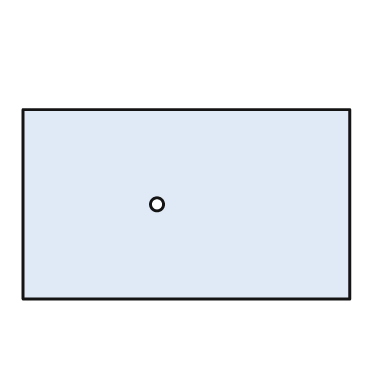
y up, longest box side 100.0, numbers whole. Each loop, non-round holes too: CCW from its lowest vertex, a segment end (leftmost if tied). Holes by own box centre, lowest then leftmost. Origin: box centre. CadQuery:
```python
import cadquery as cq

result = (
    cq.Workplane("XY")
    .moveTo(-50.0, -29.0)
    .lineTo(50.0, -29.0)
    .lineTo(50.0, 29.0)
    .lineTo(-50.0, 29.0)
    .close()
    .moveTo(-9.0, 0.0)
    .circle(2.0)
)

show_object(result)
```